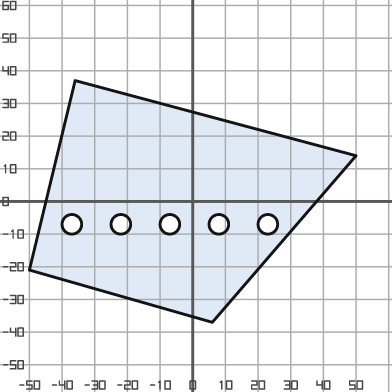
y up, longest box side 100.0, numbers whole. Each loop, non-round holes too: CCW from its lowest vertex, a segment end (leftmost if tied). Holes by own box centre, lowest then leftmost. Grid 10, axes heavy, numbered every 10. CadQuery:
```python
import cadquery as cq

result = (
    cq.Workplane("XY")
    .moveTo(6.0, -37.0)
    .lineTo(50.0, 14.0)
    .lineTo(-36.0, 37.0)
    .lineTo(-50.0, -21.0)
    .close()
    .moveTo(-37.0, -7.0)
    .circle(3.0)
    .moveTo(-22.0, -7.0)
    .circle(3.0)
    .moveTo(-7.0, -7.0)
    .circle(3.0)
    .moveTo(8.0, -7.0)
    .circle(3.0)
    .moveTo(23.0, -7.0)
    .circle(3.0)
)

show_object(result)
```